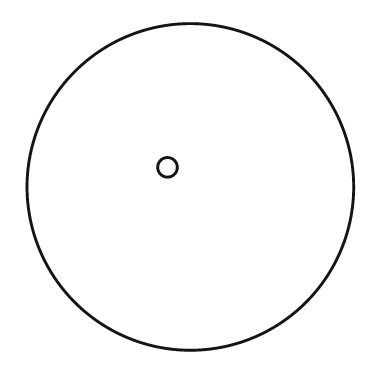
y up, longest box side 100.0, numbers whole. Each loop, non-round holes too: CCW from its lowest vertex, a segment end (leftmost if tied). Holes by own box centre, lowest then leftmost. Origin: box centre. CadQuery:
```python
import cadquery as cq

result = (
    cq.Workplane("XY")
    .moveTo(0.0, 0.0)
    .circle(50.0)
    .moveTo(-7.0, 6.0)
    .circle(3.0)
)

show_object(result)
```